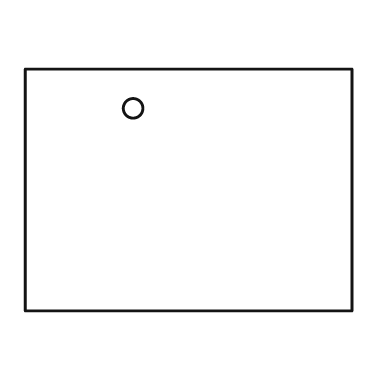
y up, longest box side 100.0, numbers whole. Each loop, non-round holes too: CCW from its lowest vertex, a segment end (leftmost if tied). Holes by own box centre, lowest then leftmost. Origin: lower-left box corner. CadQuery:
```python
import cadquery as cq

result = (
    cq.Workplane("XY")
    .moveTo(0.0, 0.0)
    .lineTo(100.0, 0.0)
    .lineTo(100.0, 74.0)
    .lineTo(0.0, 74.0)
    .close()
    .moveTo(33.0, 62.0)
    .circle(3.0)
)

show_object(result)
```